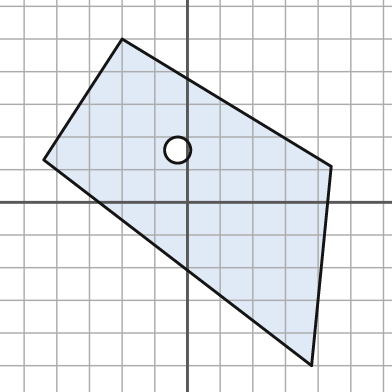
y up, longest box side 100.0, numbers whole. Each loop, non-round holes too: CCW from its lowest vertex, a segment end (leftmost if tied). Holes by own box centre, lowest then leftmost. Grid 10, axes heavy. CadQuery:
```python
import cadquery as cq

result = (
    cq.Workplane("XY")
    .moveTo(38.0, -50.0)
    .lineTo(44.0, 11.0)
    .lineTo(-20.0, 50.0)
    .lineTo(-44.0, 13.0)
    .close()
    .moveTo(-3.0, 16.0)
    .circle(4.0)
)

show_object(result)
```